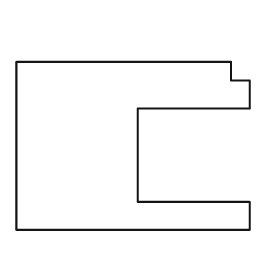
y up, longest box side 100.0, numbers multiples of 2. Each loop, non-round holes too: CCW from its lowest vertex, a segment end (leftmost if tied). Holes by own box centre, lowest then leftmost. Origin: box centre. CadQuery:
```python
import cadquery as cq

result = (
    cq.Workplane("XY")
    .moveTo(-50.0, -36.0)
    .lineTo(50.0, -36.0)
    .lineTo(50.0, -24.0)
    .lineTo(2.0, -24.0)
    .lineTo(2.0, 16.0)
    .lineTo(50.0, 16.0)
    .lineTo(50.0, 28.0)
    .lineTo(42.0, 28.0)
    .lineTo(42.0, 36.0)
    .lineTo(-50.0, 36.0)
    .close()
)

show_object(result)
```